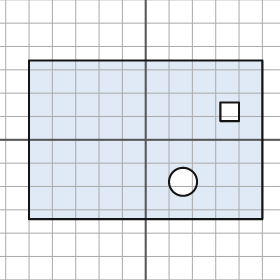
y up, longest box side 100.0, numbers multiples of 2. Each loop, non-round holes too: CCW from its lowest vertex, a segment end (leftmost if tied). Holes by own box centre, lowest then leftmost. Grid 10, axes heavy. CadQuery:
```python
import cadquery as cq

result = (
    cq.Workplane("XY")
    .moveTo(-50.0, -34.0)
    .lineTo(50.0, -34.0)
    .lineTo(50.0, 34.0)
    .lineTo(-50.0, 34.0)
    .close()
    .moveTo(16.0, -18.0)
    .circle(6.0)
    .moveTo(32.0, 8.0)
    .lineTo(40.0, 8.0)
    .lineTo(40.0, 16.0)
    .lineTo(32.0, 16.0)
    .close()
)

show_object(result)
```